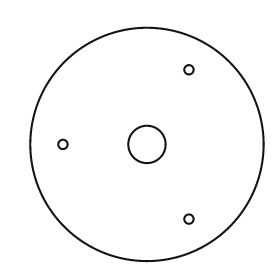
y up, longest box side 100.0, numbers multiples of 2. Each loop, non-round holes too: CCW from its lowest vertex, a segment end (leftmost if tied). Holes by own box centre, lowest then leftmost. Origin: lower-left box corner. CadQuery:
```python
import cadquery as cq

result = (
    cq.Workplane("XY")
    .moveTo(50.0, 50.0)
    .circle(50.0)
    .moveTo(68.0, 18.0)
    .circle(2.0)
    .moveTo(14.0, 50.0)
    .circle(2.0)
    .moveTo(50.0, 50.0)
    .circle(8.0)
    .moveTo(68.0, 82.0)
    .circle(2.0)
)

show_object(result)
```